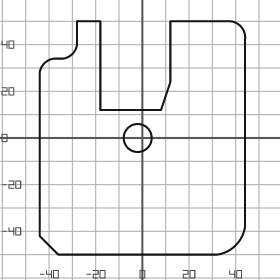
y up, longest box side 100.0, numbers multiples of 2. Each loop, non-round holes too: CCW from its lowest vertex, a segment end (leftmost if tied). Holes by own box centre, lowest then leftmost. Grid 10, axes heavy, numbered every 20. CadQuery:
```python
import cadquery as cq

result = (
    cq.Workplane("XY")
    .moveTo(-36.0, -50.0)
    .lineTo(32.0, -50.0)
    .threePointArc((40.0, -46.0), (44.0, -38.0))
    .lineTo(44.0, 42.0)
    .threePointArc((42.0, 48.0), (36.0, 50.0))
    .lineTo(12.0, 50.0)
    .lineTo(12.0, 24.0)
    .lineTo(8.0, 12.0)
    .lineTo(-18.0, 12.0)
    .lineTo(-18.0, 50.0)
    .lineTo(-28.0, 50.0)
    .lineTo(-28.0, 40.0)
    .threePointArc((-30.0, 36.0), (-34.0, 34.0))
    .lineTo(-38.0, 34.0)
    .threePointArc((-42.0, 32.0), (-44.0, 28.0))
    .lineTo(-44.0, -42.0)
    .close()
    .moveTo(-2.0, 0.0)
    .circle(6.0)
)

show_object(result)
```